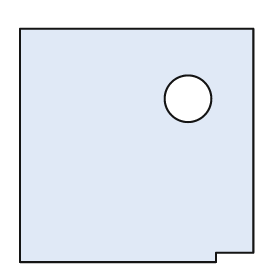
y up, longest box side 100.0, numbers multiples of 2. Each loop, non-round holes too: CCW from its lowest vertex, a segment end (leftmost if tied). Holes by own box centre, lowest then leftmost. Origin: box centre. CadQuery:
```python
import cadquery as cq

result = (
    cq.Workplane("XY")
    .moveTo(-50.0, -50.0)
    .lineTo(34.0, -50.0)
    .lineTo(34.0, -46.0)
    .lineTo(50.0, -46.0)
    .lineTo(50.0, 50.0)
    .lineTo(-50.0, 50.0)
    .close()
    .moveTo(22.0, 20.0)
    .circle(10.0)
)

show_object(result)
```